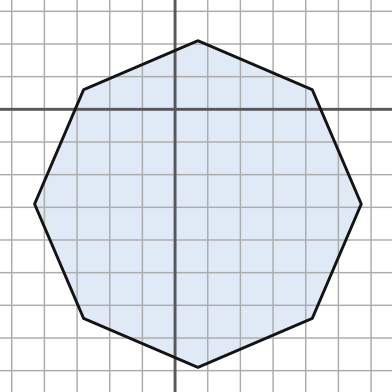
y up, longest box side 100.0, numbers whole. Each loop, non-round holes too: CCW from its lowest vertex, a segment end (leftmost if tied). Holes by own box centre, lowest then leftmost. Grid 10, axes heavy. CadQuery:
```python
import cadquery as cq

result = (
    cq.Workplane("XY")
    .moveTo(7.0, -79.0)
    .lineTo(42.0, -64.0)
    .lineTo(57.0, -29.0)
    .lineTo(42.0, 6.0)
    .lineTo(7.0, 21.0)
    .lineTo(-28.0, 6.0)
    .lineTo(-43.0, -29.0)
    .lineTo(-28.0, -64.0)
    .close()
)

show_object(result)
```